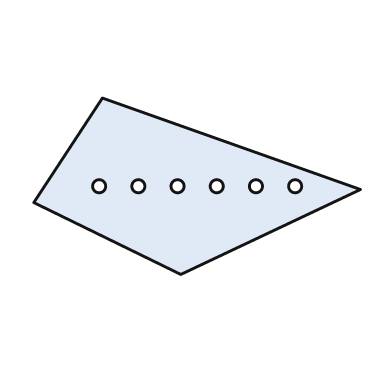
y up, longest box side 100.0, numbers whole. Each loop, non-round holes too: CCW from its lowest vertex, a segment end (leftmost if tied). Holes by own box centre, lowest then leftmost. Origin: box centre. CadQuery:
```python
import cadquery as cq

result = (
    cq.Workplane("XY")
    .moveTo(-5.0, -27.0)
    .lineTo(50.0, -1.0)
    .lineTo(-29.0, 27.0)
    .lineTo(-50.0, -5.0)
    .close()
    .moveTo(-30.0, 0.0)
    .circle(2.0)
    .moveTo(-18.0, 0.0)
    .circle(2.0)
    .moveTo(-6.0, 0.0)
    .circle(2.0)
    .moveTo(6.0, 0.0)
    .circle(2.0)
    .moveTo(18.0, 0.0)
    .circle(2.0)
    .moveTo(30.0, 0.0)
    .circle(2.0)
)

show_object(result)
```